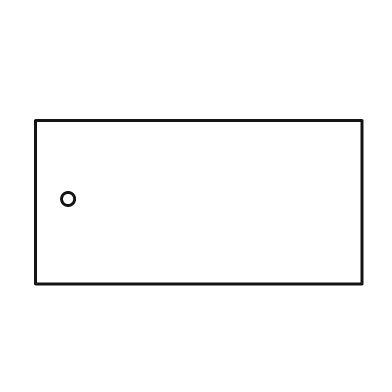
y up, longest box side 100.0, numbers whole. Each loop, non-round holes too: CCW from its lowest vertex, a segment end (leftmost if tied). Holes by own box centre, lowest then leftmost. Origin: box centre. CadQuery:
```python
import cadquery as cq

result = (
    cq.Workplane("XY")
    .moveTo(-50.0, -25.0)
    .lineTo(50.0, -25.0)
    .lineTo(50.0, 25.0)
    .lineTo(-50.0, 25.0)
    .close()
    .moveTo(-40.0, 1.0)
    .circle(2.0)
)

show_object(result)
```